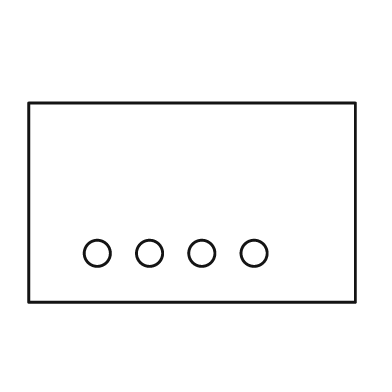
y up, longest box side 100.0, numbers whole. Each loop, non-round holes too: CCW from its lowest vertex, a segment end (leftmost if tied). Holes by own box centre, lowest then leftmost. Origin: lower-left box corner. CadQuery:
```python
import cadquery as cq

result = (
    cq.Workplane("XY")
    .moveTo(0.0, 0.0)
    .lineTo(100.0, 0.0)
    .lineTo(100.0, 61.0)
    .lineTo(0.0, 61.0)
    .close()
    .moveTo(21.0, 15.0)
    .circle(4.0)
    .moveTo(37.0, 15.0)
    .circle(4.0)
    .moveTo(53.0, 15.0)
    .circle(4.0)
    .moveTo(69.0, 15.0)
    .circle(4.0)
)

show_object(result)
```